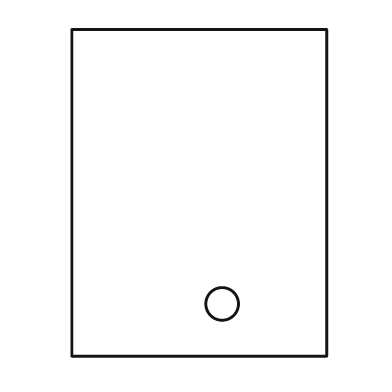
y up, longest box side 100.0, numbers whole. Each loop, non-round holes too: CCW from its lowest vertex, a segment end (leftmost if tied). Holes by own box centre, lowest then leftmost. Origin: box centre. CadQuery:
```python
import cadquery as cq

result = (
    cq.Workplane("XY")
    .moveTo(-39.0, -50.0)
    .lineTo(39.0, -50.0)
    .lineTo(39.0, 50.0)
    .lineTo(-39.0, 50.0)
    .close()
    .moveTo(7.0, -34.0)
    .circle(5.0)
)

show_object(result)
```